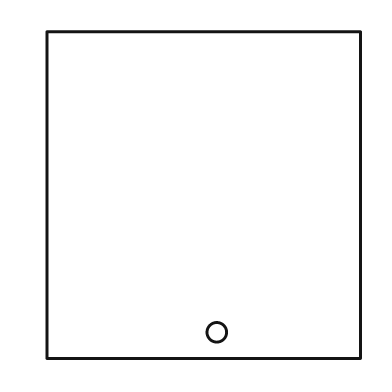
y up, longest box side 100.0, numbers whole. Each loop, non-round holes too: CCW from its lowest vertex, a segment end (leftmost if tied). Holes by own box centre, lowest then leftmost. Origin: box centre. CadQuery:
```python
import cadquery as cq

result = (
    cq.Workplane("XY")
    .moveTo(-48.0, -50.0)
    .lineTo(48.0, -50.0)
    .lineTo(48.0, 50.0)
    .lineTo(-48.0, 50.0)
    .close()
    .moveTo(4.0, -42.0)
    .circle(3.0)
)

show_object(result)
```